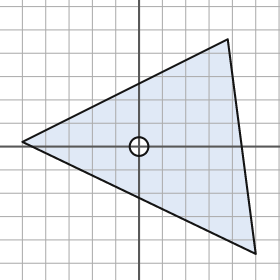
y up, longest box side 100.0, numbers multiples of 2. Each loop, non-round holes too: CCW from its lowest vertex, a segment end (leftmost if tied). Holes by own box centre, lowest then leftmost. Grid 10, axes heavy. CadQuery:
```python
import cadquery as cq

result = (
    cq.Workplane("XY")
    .moveTo(50.0, -46.0)
    .lineTo(38.0, 46.0)
    .lineTo(-50.0, 2.0)
    .close()
    .moveTo(0.0, 0.0)
    .circle(4.0)
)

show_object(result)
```